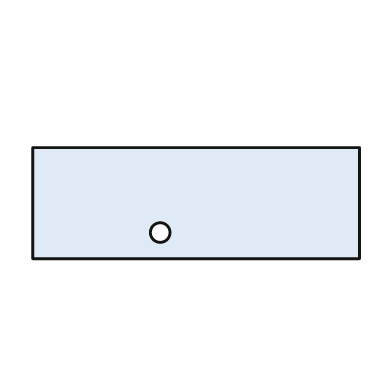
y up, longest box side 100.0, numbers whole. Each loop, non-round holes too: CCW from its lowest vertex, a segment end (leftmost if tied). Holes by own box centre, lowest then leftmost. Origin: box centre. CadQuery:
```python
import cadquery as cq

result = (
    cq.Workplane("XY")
    .moveTo(-50.0, -17.0)
    .lineTo(50.0, -17.0)
    .lineTo(50.0, 17.0)
    .lineTo(-50.0, 17.0)
    .close()
    .moveTo(-11.0, -9.0)
    .circle(3.0)
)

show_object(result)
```